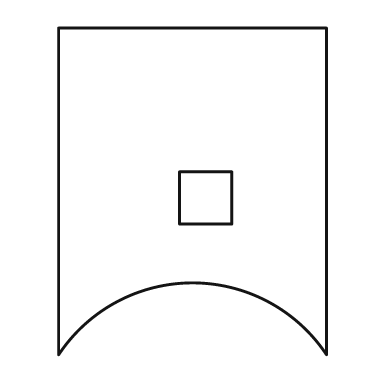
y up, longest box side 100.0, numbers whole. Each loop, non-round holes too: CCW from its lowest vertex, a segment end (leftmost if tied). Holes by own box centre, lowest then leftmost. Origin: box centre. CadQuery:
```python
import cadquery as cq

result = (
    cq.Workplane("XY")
    .moveTo(-41.0, -50.0)
    .threePointArc((0.0, -28.0), (41.0, -50.0))
    .lineTo(41.0, 50.0)
    .lineTo(-41.0, 50.0)
    .close()
    .moveTo(-4.0, -10.0)
    .lineTo(12.0, -10.0)
    .lineTo(12.0, 6.0)
    .lineTo(-4.0, 6.0)
    .close()
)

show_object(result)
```